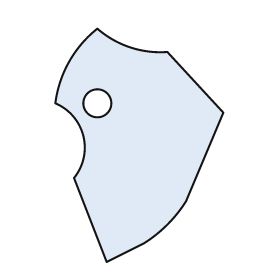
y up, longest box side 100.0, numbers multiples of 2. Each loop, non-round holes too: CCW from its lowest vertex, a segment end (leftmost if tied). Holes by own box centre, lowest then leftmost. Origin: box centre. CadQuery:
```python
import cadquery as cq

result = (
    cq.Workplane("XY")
    .moveTo(-14.0, -50.0)
    .lineTo(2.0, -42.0)
    .threePointArc((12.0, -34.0), (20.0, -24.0))
    .lineTo(36.0, 14.0)
    .lineTo(12.0, 40.0)
    .threePointArc((-4.0, 42.0), (-18.0, 50.0))
    .threePointArc((-30.0, 36.0), (-36.0, 18.0))
    .threePointArc((-24.0, 4.0), (-28.0, -14.0))
    .close()
    .moveTo(-18.0, 18.0)
    .circle(6.0)
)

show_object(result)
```